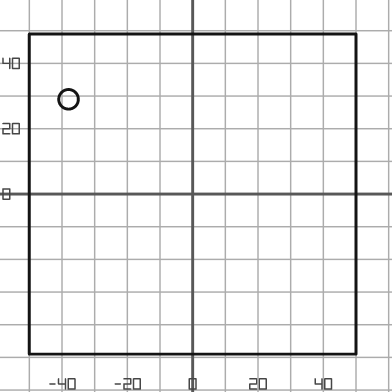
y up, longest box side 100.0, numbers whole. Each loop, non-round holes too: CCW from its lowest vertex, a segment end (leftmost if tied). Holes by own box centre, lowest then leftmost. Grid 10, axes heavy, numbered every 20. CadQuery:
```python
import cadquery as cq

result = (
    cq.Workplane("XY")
    .moveTo(-50.0, -49.0)
    .lineTo(50.0, -49.0)
    .lineTo(50.0, 49.0)
    .lineTo(-50.0, 49.0)
    .close()
    .moveTo(-38.0, 29.0)
    .circle(3.0)
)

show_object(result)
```